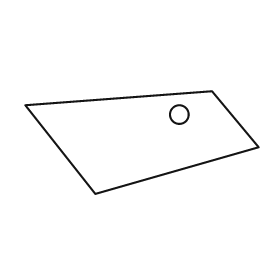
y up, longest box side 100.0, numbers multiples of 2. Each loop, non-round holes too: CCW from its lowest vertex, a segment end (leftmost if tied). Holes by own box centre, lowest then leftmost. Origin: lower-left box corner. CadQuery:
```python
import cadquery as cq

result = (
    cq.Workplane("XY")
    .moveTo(30.0, 0.0)
    .lineTo(100.0, 20.0)
    .lineTo(80.0, 44.0)
    .lineTo(0.0, 38.0)
    .close()
    .moveTo(66.0, 34.0)
    .circle(4.0)
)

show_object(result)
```